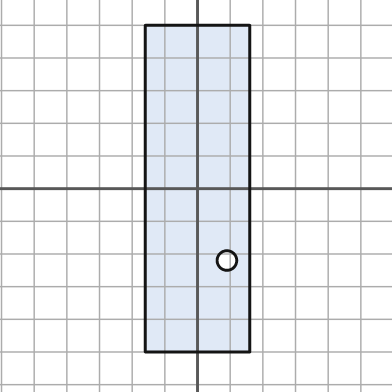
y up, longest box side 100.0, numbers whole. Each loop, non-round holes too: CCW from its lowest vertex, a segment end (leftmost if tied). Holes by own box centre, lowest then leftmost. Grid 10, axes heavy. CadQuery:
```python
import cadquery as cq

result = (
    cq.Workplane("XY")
    .moveTo(-16.0, -50.0)
    .lineTo(16.0, -50.0)
    .lineTo(16.0, 50.0)
    .lineTo(-16.0, 50.0)
    .close()
    .moveTo(9.0, -22.0)
    .circle(3.0)
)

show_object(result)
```